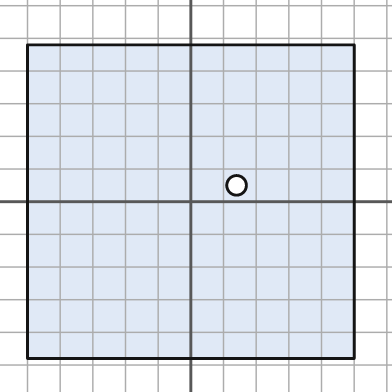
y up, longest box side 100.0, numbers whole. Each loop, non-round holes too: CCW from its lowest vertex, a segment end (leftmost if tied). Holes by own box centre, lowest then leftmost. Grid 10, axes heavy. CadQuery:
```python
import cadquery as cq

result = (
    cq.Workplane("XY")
    .moveTo(-50.0, -48.0)
    .lineTo(50.0, -48.0)
    .lineTo(50.0, 48.0)
    .lineTo(-50.0, 48.0)
    .close()
    .moveTo(14.0, 5.0)
    .circle(3.0)
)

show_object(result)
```